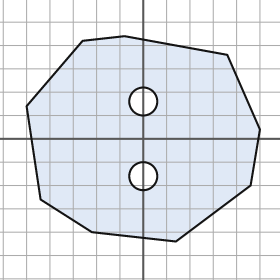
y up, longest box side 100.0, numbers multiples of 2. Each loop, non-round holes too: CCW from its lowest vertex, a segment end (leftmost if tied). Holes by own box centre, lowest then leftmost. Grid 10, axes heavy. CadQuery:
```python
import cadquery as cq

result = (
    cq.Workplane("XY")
    .moveTo(14.0, -44.0)
    .lineTo(46.0, -20.0)
    .lineTo(50.0, 4.0)
    .lineTo(36.0, 36.0)
    .lineTo(-8.0, 44.0)
    .lineTo(-26.0, 42.0)
    .lineTo(-50.0, 14.0)
    .lineTo(-44.0, -26.0)
    .lineTo(-22.0, -40.0)
    .close()
    .moveTo(0.0, -16.0)
    .circle(6.0)
    .moveTo(0.0, 16.0)
    .circle(6.0)
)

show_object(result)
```